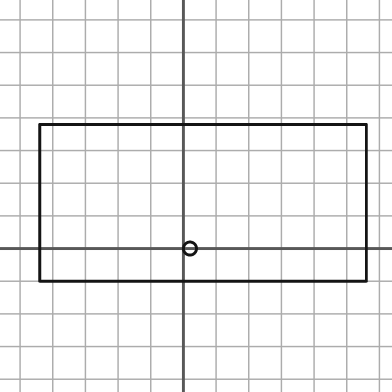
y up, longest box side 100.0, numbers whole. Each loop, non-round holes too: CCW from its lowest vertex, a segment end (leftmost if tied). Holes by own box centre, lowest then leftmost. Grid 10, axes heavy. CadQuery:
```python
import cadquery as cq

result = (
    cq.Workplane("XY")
    .moveTo(-44.0, -10.0)
    .lineTo(56.0, -10.0)
    .lineTo(56.0, 38.0)
    .lineTo(-44.0, 38.0)
    .close()
    .moveTo(2.0, 0.0)
    .circle(2.0)
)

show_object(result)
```